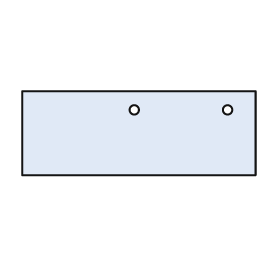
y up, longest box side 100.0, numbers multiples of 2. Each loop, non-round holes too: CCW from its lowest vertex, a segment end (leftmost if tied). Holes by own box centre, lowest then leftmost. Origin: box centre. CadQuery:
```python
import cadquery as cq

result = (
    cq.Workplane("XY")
    .moveTo(-50.0, -18.0)
    .lineTo(50.0, -18.0)
    .lineTo(50.0, 18.0)
    .lineTo(-50.0, 18.0)
    .close()
    .moveTo(-2.0, 10.0)
    .circle(2.0)
    .moveTo(38.0, 10.0)
    .circle(2.0)
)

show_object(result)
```